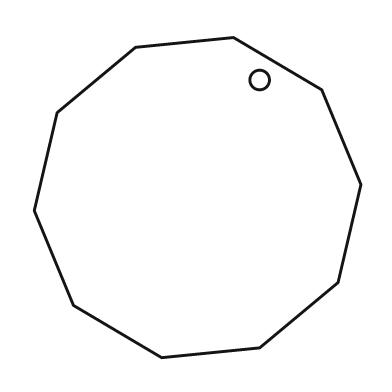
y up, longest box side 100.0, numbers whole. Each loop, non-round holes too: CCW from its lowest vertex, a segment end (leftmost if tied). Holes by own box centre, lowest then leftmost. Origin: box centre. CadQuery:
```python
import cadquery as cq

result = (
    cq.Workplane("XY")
    .moveTo(-11.0, -49.0)
    .lineTo(19.0, -46.0)
    .lineTo(43.0, -26.0)
    .lineTo(50.0, 4.0)
    .lineTo(38.0, 33.0)
    .lineTo(11.0, 49.0)
    .lineTo(-19.0, 46.0)
    .lineTo(-43.0, 26.0)
    .lineTo(-50.0, -4.0)
    .lineTo(-38.0, -33.0)
    .close()
    .moveTo(19.0, 36.0)
    .circle(3.0)
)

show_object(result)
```